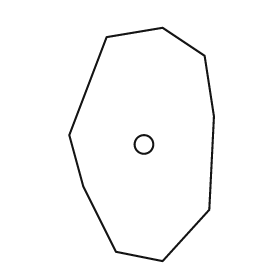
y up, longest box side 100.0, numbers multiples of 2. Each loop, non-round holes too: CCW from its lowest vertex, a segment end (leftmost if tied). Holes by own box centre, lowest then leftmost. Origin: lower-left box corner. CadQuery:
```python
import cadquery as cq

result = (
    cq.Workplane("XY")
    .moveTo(40.0, 0.0)
    .lineTo(60.0, 22.0)
    .lineTo(62.0, 62.0)
    .lineTo(58.0, 88.0)
    .lineTo(40.0, 100.0)
    .lineTo(16.0, 96.0)
    .lineTo(0.0, 54.0)
    .lineTo(6.0, 32.0)
    .lineTo(20.0, 4.0)
    .close()
    .moveTo(32.0, 50.0)
    .circle(4.0)
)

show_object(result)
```